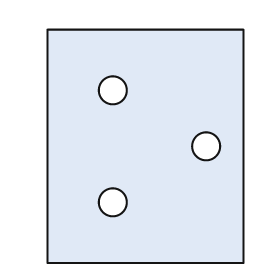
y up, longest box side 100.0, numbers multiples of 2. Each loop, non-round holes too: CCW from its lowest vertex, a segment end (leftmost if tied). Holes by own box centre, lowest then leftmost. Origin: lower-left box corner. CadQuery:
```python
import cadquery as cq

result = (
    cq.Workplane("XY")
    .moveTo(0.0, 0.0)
    .lineTo(84.0, 0.0)
    .lineTo(84.0, 100.0)
    .lineTo(0.0, 100.0)
    .close()
    .moveTo(28.0, 26.0)
    .circle(6.0)
    .moveTo(68.0, 50.0)
    .circle(6.0)
    .moveTo(28.0, 74.0)
    .circle(6.0)
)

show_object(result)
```